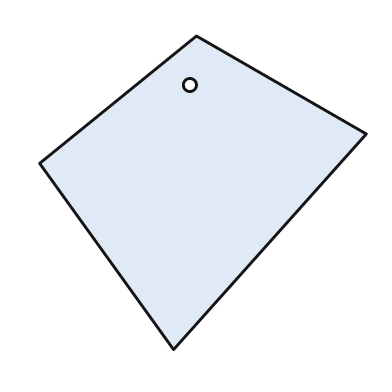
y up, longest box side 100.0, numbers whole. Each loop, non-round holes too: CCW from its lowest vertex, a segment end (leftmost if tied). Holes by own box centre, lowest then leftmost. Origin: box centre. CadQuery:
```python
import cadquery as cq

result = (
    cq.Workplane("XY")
    .moveTo(-9.0, -48.0)
    .lineTo(50.0, 18.0)
    .lineTo(-2.0, 48.0)
    .lineTo(-50.0, 9.0)
    .close()
    .moveTo(-4.0, 33.0)
    .circle(2.0)
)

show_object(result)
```